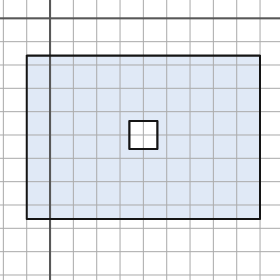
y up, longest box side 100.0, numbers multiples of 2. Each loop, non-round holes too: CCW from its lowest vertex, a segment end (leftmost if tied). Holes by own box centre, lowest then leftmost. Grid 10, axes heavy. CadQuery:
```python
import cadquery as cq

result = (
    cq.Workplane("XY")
    .moveTo(-10.0, -86.0)
    .lineTo(90.0, -86.0)
    .lineTo(90.0, -16.0)
    .lineTo(-10.0, -16.0)
    .close()
    .moveTo(34.0, -56.0)
    .lineTo(46.0, -56.0)
    .lineTo(46.0, -44.0)
    .lineTo(34.0, -44.0)
    .close()
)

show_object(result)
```